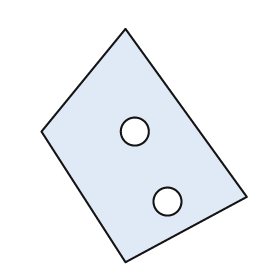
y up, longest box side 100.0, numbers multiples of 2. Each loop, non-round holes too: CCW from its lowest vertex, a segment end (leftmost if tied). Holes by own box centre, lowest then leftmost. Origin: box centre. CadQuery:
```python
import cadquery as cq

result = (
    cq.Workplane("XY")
    .moveTo(-8.0, -50.0)
    .lineTo(44.0, -22.0)
    .lineTo(-8.0, 50.0)
    .lineTo(-44.0, 6.0)
    .close()
    .moveTo(10.0, -24.0)
    .circle(6.0)
    .moveTo(-4.0, 6.0)
    .circle(6.0)
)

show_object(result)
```